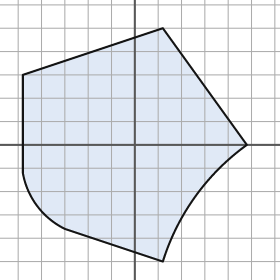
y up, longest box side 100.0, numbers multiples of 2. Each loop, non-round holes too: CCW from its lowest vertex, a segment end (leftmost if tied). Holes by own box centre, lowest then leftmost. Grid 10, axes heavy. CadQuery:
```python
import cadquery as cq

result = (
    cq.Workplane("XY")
    .moveTo(12.0, -50.0)
    .threePointArc((26.0, -22.0), (48.0, 0.0))
    .lineTo(12.0, 50.0)
    .lineTo(-48.0, 30.0)
    .lineTo(-48.0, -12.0)
    .threePointArc((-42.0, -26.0), (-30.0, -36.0))
    .close()
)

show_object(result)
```